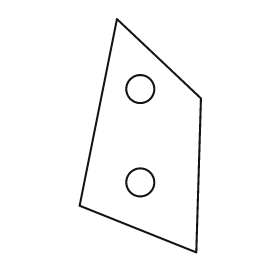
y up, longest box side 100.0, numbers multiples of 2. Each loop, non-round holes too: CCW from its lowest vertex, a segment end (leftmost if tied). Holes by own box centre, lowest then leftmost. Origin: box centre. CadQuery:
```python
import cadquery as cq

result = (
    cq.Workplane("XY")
    .moveTo(24.0, -50.0)
    .lineTo(26.0, 16.0)
    .lineTo(-10.0, 50.0)
    .lineTo(-26.0, -30.0)
    .close()
    .moveTo(0.0, -20.0)
    .circle(6.0)
    .moveTo(0.0, 20.0)
    .circle(6.0)
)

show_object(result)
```